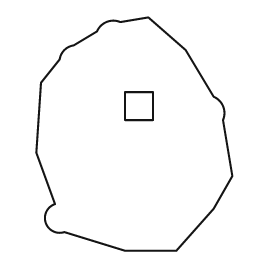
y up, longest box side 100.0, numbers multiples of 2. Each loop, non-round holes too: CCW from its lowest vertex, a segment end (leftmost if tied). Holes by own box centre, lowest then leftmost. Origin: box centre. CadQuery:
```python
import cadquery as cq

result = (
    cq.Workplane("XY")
    .moveTo(-4.0, -50.0)
    .lineTo(18.0, -50.0)
    .lineTo(34.0, -32.0)
    .lineTo(42.0, -18.0)
    .lineTo(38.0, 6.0)
    .threePointArc((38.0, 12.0), (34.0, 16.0))
    .lineTo(22.0, 36.0)
    .lineTo(6.0, 50.0)
    .lineTo(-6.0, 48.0)
    .threePointArc((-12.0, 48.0), (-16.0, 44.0))
    .lineTo(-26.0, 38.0)
    .threePointArc((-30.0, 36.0), (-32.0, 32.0))
    .lineTo(-40.0, 22.0)
    .lineTo(-42.0, -8.0)
    .lineTo(-34.0, -30.0)
    .threePointArc((-38.0, -38.0), (-30.0, -42.0))
    .close()
    .moveTo(-4.0, 6.0)
    .lineTo(8.0, 6.0)
    .lineTo(8.0, 18.0)
    .lineTo(-4.0, 18.0)
    .close()
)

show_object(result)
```